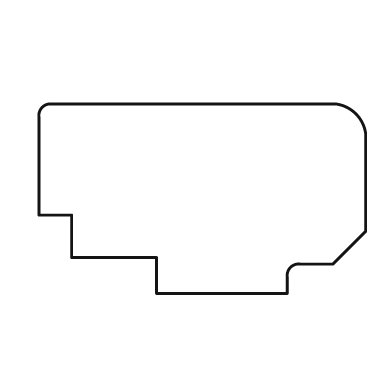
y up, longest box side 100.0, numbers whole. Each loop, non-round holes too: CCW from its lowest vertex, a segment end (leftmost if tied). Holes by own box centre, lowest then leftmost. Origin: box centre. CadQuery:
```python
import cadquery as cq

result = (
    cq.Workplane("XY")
    .moveTo(-14.0, -29.0)
    .lineTo(26.0, -29.0)
    .lineTo(26.0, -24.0)
    .threePointArc((27.0, -21.0), (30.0, -20.0))
    .lineTo(40.0, -20.0)
    .lineTo(50.0, -10.0)
    .lineTo(50.0, 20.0)
    .threePointArc((47.0, 26.0), (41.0, 29.0))
    .lineTo(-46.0, 29.0)
    .threePointArc((-49.0, 28.0), (-50.0, 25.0))
    .lineTo(-50.0, -5.0)
    .lineTo(-40.0, -5.0)
    .lineTo(-40.0, -18.0)
    .lineTo(-14.0, -18.0)
    .close()
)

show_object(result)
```